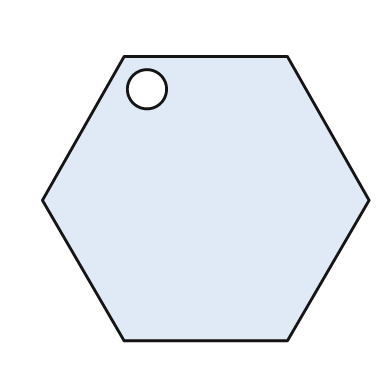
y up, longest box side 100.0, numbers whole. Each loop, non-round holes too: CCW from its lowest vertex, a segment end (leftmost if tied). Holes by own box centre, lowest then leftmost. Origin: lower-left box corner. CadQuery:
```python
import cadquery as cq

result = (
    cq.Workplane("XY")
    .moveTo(25.0, 0.0)
    .lineTo(75.0, 0.0)
    .lineTo(100.0, 43.0)
    .lineTo(75.0, 87.0)
    .lineTo(25.0, 87.0)
    .lineTo(0.0, 43.0)
    .close()
    .moveTo(32.0, 77.0)
    .circle(6.0)
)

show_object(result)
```